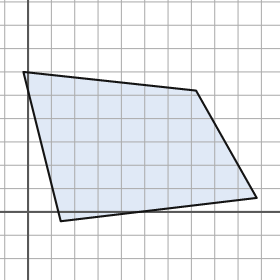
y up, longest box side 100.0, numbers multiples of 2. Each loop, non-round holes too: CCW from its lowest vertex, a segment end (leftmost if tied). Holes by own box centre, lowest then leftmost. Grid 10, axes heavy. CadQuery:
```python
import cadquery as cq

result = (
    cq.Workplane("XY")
    .moveTo(14.0, -4.0)
    .lineTo(98.0, 6.0)
    .lineTo(72.0, 52.0)
    .lineTo(-2.0, 60.0)
    .close()
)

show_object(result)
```